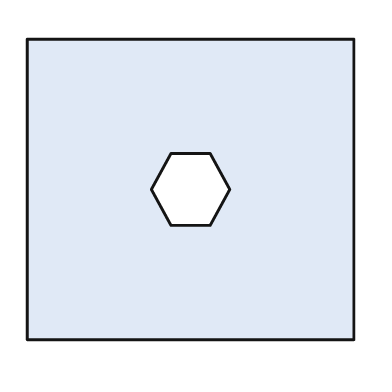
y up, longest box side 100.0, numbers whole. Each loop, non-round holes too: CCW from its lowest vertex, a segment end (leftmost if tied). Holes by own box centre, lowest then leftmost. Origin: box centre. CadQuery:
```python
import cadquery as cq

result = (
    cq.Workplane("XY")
    .moveTo(-50.0, -46.0)
    .lineTo(50.0, -46.0)
    .lineTo(50.0, 46.0)
    .lineTo(-50.0, 46.0)
    .close()
    .moveTo(-6.0, -11.0)
    .lineTo(6.0, -11.0)
    .lineTo(12.0, 0.0)
    .lineTo(6.0, 11.0)
    .lineTo(-6.0, 11.0)
    .lineTo(-12.0, 0.0)
    .close()
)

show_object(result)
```